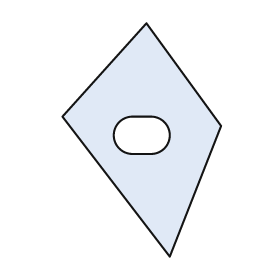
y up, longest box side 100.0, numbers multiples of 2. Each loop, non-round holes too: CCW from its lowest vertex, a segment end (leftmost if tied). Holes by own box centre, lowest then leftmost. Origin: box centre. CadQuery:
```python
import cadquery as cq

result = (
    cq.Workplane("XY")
    .moveTo(12.0, -50.0)
    .lineTo(34.0, 6.0)
    .lineTo(2.0, 50.0)
    .lineTo(-34.0, 10.0)
    .close()
    .moveTo(-4.0, -6.0)
    .lineTo(4.0, -6.0)
    .threePointArc((12.0, 2.0), (4.0, 10.0))
    .lineTo(-4.0, 10.0)
    .threePointArc((-12.0, 2.0), (-4.0, -6.0))
    .close()
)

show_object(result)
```